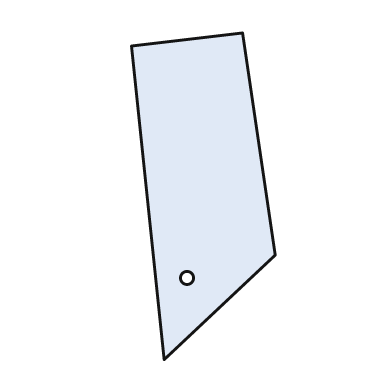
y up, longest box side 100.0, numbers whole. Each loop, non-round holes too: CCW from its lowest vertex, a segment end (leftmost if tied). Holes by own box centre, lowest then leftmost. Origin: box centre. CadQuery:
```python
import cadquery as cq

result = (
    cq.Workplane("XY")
    .moveTo(-12.0, -50.0)
    .lineTo(22.0, -18.0)
    .lineTo(12.0, 50.0)
    .lineTo(-22.0, 46.0)
    .close()
    .moveTo(-5.0, -25.0)
    .circle(2.0)
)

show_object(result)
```